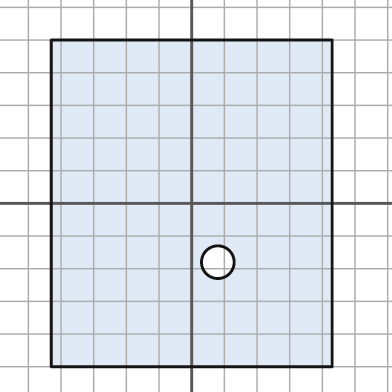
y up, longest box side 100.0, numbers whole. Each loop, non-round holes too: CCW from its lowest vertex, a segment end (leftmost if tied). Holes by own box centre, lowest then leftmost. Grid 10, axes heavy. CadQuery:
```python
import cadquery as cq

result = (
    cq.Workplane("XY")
    .moveTo(-43.0, -50.0)
    .lineTo(43.0, -50.0)
    .lineTo(43.0, 50.0)
    .lineTo(-43.0, 50.0)
    .close()
    .moveTo(8.0, -18.0)
    .circle(5.0)
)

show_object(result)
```